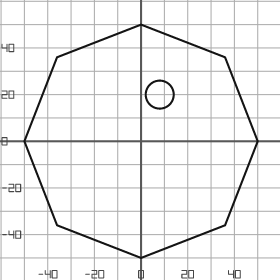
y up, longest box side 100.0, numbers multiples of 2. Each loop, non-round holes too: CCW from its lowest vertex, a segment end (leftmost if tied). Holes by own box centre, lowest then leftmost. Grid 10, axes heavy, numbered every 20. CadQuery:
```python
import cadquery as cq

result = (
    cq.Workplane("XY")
    .moveTo(0.0, -50.0)
    .lineTo(36.0, -36.0)
    .lineTo(50.0, 0.0)
    .lineTo(36.0, 36.0)
    .lineTo(0.0, 50.0)
    .lineTo(-36.0, 36.0)
    .lineTo(-50.0, 0.0)
    .lineTo(-36.0, -36.0)
    .close()
    .moveTo(8.0, 20.0)
    .circle(6.0)
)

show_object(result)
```